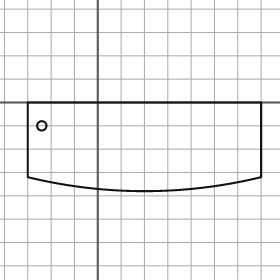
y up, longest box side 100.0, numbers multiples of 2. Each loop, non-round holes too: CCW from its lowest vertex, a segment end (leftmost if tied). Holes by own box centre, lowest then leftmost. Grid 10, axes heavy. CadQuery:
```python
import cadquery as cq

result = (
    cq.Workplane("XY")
    .moveTo(-30.0, -32.0)
    .threePointArc((20.0, -38.0), (70.0, -32.0))
    .lineTo(70.0, 0.0)
    .lineTo(-30.0, 0.0)
    .close()
    .moveTo(-24.0, -10.0)
    .circle(2.0)
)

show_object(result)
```